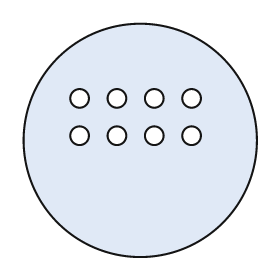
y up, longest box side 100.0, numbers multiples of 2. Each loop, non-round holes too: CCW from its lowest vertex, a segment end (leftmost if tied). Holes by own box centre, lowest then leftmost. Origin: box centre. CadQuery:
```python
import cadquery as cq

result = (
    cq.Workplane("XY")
    .moveTo(0.0, 0.0)
    .circle(50.0)
    .moveTo(-26.0, 2.0)
    .circle(4.0)
    .moveTo(-10.0, 2.0)
    .circle(4.0)
    .moveTo(6.0, 2.0)
    .circle(4.0)
    .moveTo(22.0, 2.0)
    .circle(4.0)
    .moveTo(-26.0, 18.0)
    .circle(4.0)
    .moveTo(-10.0, 18.0)
    .circle(4.0)
    .moveTo(6.0, 18.0)
    .circle(4.0)
    .moveTo(22.0, 18.0)
    .circle(4.0)
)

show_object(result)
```